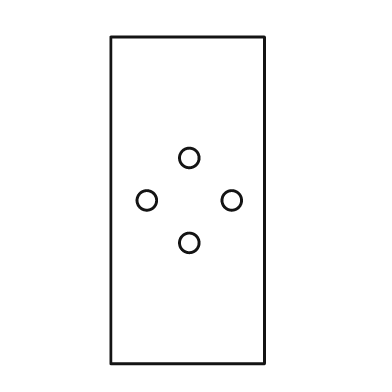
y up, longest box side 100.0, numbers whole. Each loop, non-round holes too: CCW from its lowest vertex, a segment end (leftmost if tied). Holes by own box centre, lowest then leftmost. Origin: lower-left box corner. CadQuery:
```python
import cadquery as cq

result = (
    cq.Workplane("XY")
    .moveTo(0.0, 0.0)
    .lineTo(47.0, 0.0)
    .lineTo(47.0, 100.0)
    .lineTo(0.0, 100.0)
    .close()
    .moveTo(24.0, 37.0)
    .circle(3.0)
    .moveTo(11.0, 50.0)
    .circle(3.0)
    .moveTo(37.0, 50.0)
    .circle(3.0)
    .moveTo(24.0, 63.0)
    .circle(3.0)
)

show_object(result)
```